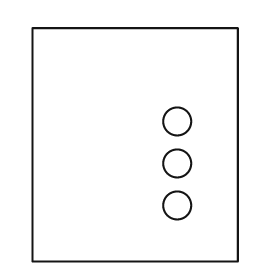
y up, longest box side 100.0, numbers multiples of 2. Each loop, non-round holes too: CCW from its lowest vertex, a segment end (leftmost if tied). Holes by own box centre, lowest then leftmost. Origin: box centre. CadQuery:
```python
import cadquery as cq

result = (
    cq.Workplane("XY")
    .moveTo(-44.0, -50.0)
    .lineTo(44.0, -50.0)
    .lineTo(44.0, 50.0)
    .lineTo(-44.0, 50.0)
    .close()
    .moveTo(18.0, -26.0)
    .circle(6.0)
    .moveTo(18.0, -8.0)
    .circle(6.0)
    .moveTo(18.0, 10.0)
    .circle(6.0)
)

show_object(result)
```